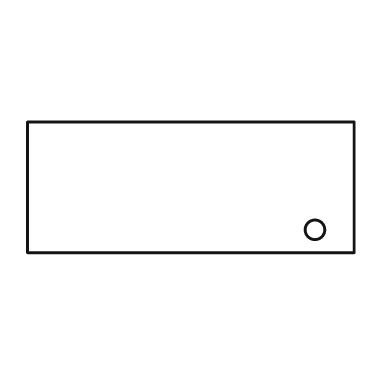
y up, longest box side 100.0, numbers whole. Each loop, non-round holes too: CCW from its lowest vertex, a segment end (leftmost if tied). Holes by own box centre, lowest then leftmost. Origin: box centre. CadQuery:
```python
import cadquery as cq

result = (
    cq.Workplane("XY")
    .moveTo(-50.0, -20.0)
    .lineTo(50.0, -20.0)
    .lineTo(50.0, 20.0)
    .lineTo(-50.0, 20.0)
    .close()
    .moveTo(38.0, -13.0)
    .circle(3.0)
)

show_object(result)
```